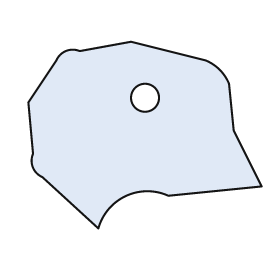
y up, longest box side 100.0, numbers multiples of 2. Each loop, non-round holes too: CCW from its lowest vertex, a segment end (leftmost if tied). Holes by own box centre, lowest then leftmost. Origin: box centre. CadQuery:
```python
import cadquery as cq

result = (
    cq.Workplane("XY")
    .moveTo(-20.0, -40.0)
    .threePointArc((-8.0, -26.0), (10.0, -26.0))
    .lineTo(50.0, -22.0)
    .lineTo(38.0, 2.0)
    .lineTo(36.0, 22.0)
    .threePointArc((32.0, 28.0), (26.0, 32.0))
    .lineTo(-6.0, 40.0)
    .lineTo(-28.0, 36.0)
    .threePointArc((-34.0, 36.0), (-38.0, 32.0))
    .lineTo(-50.0, 14.0)
    .lineTo(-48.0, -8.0)
    .threePointArc((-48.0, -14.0), (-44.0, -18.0))
    .close()
    .moveTo(0.0, 16.0)
    .circle(6.0)
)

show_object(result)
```